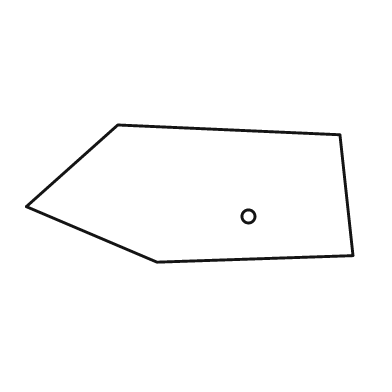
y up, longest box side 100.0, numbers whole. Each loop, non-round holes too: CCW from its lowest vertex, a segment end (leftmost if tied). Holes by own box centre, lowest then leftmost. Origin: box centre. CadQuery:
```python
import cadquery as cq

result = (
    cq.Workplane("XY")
    .moveTo(-10.0, -21.0)
    .lineTo(50.0, -19.0)
    .lineTo(46.0, 18.0)
    .lineTo(-22.0, 21.0)
    .lineTo(-50.0, -4.0)
    .close()
    .moveTo(18.0, -7.0)
    .circle(2.0)
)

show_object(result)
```